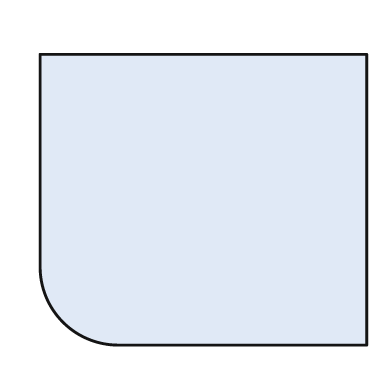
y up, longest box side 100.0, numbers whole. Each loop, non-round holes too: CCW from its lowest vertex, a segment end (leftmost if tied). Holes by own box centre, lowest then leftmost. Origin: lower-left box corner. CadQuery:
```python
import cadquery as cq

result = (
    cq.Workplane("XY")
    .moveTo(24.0, 0.0)
    .lineTo(100.0, 0.0)
    .lineTo(100.0, 89.0)
    .lineTo(0.0, 89.0)
    .lineTo(0.0, 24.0)
    .threePointArc((7.0, 7.0), (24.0, 0.0))
    .close()
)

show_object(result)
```